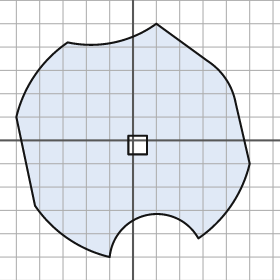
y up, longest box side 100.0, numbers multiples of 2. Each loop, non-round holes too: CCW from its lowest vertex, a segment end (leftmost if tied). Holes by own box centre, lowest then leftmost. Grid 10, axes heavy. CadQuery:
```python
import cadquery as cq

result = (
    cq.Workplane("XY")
    .moveTo(-10.0, -50.0)
    .threePointArc((6.0, -32.0), (28.0, -42.0))
    .threePointArc((42.0, -28.0), (50.0, -10.0))
    .lineTo(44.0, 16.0)
    .threePointArc((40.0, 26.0), (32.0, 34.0))
    .lineTo(10.0, 50.0)
    .threePointArc((-8.0, 42.0), (-28.0, 42.0))
    .threePointArc((-42.0, 28.0), (-50.0, 10.0))
    .lineTo(-42.0, -28.0)
    .threePointArc((-28.0, -42.0), (-10.0, -50.0))
    .close()
    .moveTo(-2.0, -6.0)
    .lineTo(6.0, -6.0)
    .lineTo(6.0, 2.0)
    .lineTo(-2.0, 2.0)
    .close()
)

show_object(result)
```